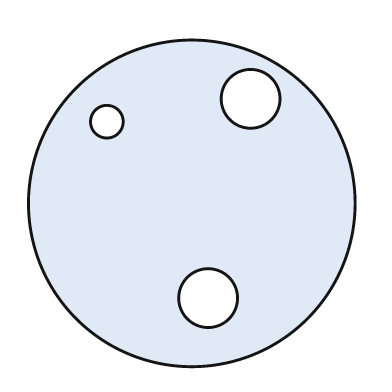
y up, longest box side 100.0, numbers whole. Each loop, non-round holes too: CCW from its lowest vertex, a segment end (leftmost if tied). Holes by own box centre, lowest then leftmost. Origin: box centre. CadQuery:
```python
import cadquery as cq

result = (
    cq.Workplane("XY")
    .moveTo(0.0, 0.0)
    .circle(50.0)
    .moveTo(5.0, -29.0)
    .circle(9.0)
    .moveTo(-26.0, 25.0)
    .circle(5.0)
    .moveTo(18.0, 32.0)
    .circle(9.0)
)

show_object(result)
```